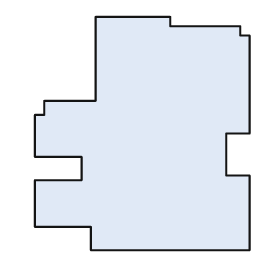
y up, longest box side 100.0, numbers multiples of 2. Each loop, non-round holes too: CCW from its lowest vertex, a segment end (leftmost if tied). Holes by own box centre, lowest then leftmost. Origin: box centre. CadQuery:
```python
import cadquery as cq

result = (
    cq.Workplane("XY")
    .moveTo(-22.0, -50.0)
    .lineTo(46.0, -50.0)
    .lineTo(46.0, -18.0)
    .lineTo(36.0, -18.0)
    .lineTo(36.0, 0.0)
    .lineTo(46.0, 0.0)
    .lineTo(46.0, 42.0)
    .lineTo(42.0, 42.0)
    .lineTo(42.0, 46.0)
    .lineTo(12.0, 46.0)
    .lineTo(12.0, 50.0)
    .lineTo(-20.0, 50.0)
    .lineTo(-20.0, 14.0)
    .lineTo(-42.0, 14.0)
    .lineTo(-42.0, 8.0)
    .lineTo(-46.0, 8.0)
    .lineTo(-46.0, -10.0)
    .lineTo(-26.0, -10.0)
    .lineTo(-26.0, -20.0)
    .lineTo(-46.0, -20.0)
    .lineTo(-46.0, -40.0)
    .lineTo(-22.0, -40.0)
    .close()
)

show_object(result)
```